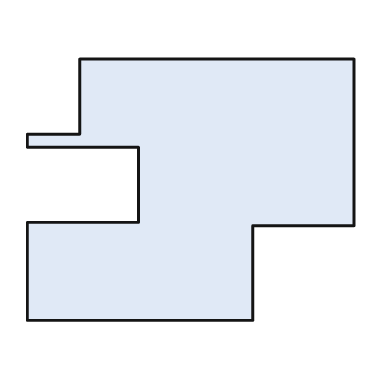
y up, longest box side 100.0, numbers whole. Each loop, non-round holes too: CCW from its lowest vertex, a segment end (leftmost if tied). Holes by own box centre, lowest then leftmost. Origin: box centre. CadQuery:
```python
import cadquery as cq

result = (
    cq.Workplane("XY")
    .moveTo(-50.0, -40.0)
    .lineTo(19.0, -40.0)
    .lineTo(19.0, -11.0)
    .lineTo(50.0, -11.0)
    .lineTo(50.0, 40.0)
    .lineTo(-34.0, 40.0)
    .lineTo(-34.0, 17.0)
    .lineTo(-50.0, 17.0)
    .lineTo(-50.0, 13.0)
    .lineTo(-16.0, 13.0)
    .lineTo(-16.0, -10.0)
    .lineTo(-50.0, -10.0)
    .close()
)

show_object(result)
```